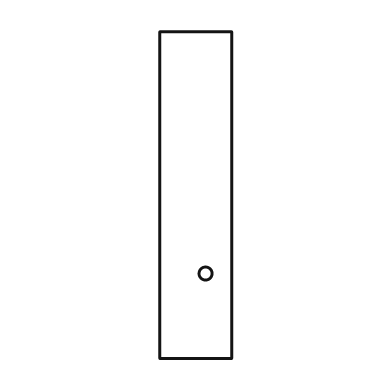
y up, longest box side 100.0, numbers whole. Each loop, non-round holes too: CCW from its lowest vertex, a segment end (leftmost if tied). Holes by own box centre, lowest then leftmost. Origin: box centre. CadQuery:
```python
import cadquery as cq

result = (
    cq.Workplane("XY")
    .moveTo(-11.0, -50.0)
    .lineTo(11.0, -50.0)
    .lineTo(11.0, 50.0)
    .lineTo(-11.0, 50.0)
    .close()
    .moveTo(3.0, -24.0)
    .circle(2.0)
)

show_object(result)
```